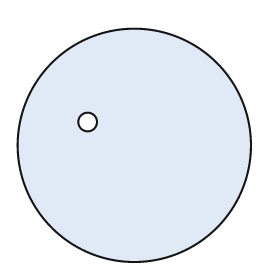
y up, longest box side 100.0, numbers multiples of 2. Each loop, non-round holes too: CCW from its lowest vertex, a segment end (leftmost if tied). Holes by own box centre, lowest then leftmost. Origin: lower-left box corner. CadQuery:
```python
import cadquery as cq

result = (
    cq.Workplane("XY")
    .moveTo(50.0, 50.0)
    .circle(50.0)
    .moveTo(30.0, 60.0)
    .circle(4.0)
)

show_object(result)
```